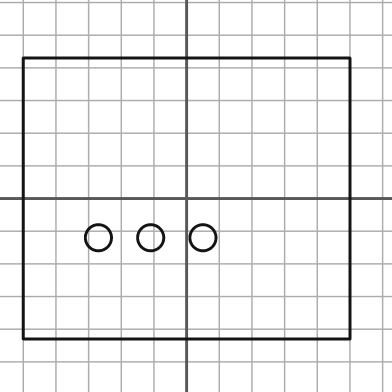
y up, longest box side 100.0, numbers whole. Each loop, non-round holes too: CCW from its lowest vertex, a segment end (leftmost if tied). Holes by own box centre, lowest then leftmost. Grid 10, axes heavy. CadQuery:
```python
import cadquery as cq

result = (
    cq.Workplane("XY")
    .moveTo(-50.0, -43.0)
    .lineTo(50.0, -43.0)
    .lineTo(50.0, 43.0)
    .lineTo(-50.0, 43.0)
    .close()
    .moveTo(-27.0, -12.0)
    .circle(4.0)
    .moveTo(-11.0, -12.0)
    .circle(4.0)
    .moveTo(5.0, -12.0)
    .circle(4.0)
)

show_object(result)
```